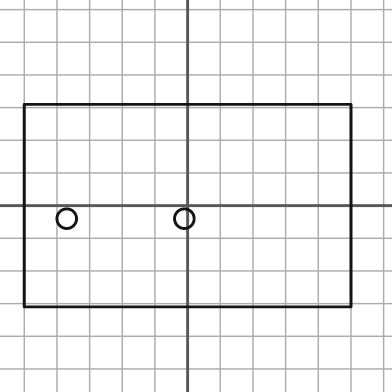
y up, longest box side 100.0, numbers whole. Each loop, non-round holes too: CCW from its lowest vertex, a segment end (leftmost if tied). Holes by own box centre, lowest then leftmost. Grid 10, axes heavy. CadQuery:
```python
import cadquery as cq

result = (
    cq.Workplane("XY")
    .moveTo(-50.0, -31.0)
    .lineTo(50.0, -31.0)
    .lineTo(50.0, 31.0)
    .lineTo(-50.0, 31.0)
    .close()
    .moveTo(-37.0, -4.0)
    .circle(3.0)
    .moveTo(-1.0, -4.0)
    .circle(3.0)
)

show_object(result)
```